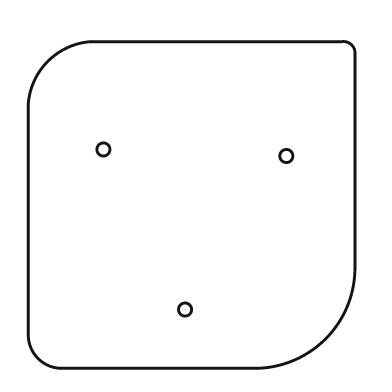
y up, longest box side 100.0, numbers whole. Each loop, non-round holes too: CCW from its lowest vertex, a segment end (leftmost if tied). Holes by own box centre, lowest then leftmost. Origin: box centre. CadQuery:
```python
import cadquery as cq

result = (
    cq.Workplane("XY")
    .moveTo(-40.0, -50.0)
    .lineTo(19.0, -50.0)
    .threePointArc((41.0, -41.0), (50.0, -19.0))
    .lineTo(50.0, 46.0)
    .threePointArc((49.0, 49.0), (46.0, 50.0))
    .lineTo(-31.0, 50.0)
    .threePointArc((-44.0, 44.0), (-50.0, 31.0))
    .lineTo(-50.0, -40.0)
    .threePointArc((-47.0, -47.0), (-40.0, -50.0))
    .close()
    .moveTo(-2.0, -32.0)
    .circle(2.0)
    .moveTo(29.0, 15.0)
    .circle(2.0)
    .moveTo(-27.0, 17.0)
    .circle(2.0)
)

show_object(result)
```